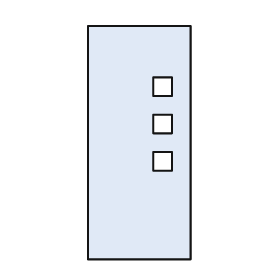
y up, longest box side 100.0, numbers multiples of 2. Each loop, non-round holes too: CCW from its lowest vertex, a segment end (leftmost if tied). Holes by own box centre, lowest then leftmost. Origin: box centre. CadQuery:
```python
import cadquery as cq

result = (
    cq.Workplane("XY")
    .moveTo(-22.0, -50.0)
    .lineTo(22.0, -50.0)
    .lineTo(22.0, 50.0)
    .lineTo(-22.0, 50.0)
    .close()
    .moveTo(6.0, -12.0)
    .lineTo(14.0, -12.0)
    .lineTo(14.0, -4.0)
    .lineTo(6.0, -4.0)
    .close()
    .moveTo(6.0, 4.0)
    .lineTo(14.0, 4.0)
    .lineTo(14.0, 12.0)
    .lineTo(6.0, 12.0)
    .close()
    .moveTo(6.0, 20.0)
    .lineTo(14.0, 20.0)
    .lineTo(14.0, 28.0)
    .lineTo(6.0, 28.0)
    .close()
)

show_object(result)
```